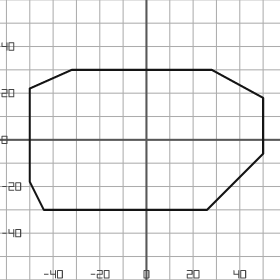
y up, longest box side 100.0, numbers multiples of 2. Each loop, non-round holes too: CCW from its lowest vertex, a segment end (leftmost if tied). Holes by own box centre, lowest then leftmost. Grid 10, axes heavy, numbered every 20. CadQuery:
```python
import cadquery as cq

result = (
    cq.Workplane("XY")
    .moveTo(-44.0, -30.0)
    .lineTo(26.0, -30.0)
    .lineTo(50.0, -6.0)
    .lineTo(50.0, 18.0)
    .lineTo(28.0, 30.0)
    .lineTo(-32.0, 30.0)
    .lineTo(-50.0, 22.0)
    .lineTo(-50.0, -18.0)
    .close()
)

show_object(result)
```